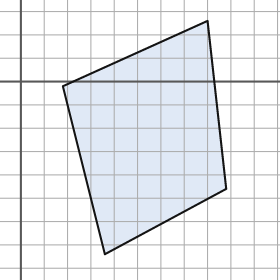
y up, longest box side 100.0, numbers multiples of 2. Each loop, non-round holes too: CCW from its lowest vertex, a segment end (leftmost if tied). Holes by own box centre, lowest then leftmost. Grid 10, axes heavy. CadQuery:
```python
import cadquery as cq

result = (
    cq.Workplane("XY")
    .moveTo(36.0, -74.0)
    .lineTo(88.0, -46.0)
    .lineTo(80.0, 26.0)
    .lineTo(18.0, -2.0)
    .close()
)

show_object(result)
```